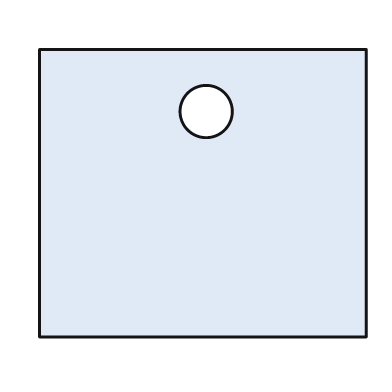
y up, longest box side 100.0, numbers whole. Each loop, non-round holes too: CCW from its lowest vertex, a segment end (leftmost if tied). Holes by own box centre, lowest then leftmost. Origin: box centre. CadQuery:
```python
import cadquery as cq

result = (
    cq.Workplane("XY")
    .moveTo(-50.0, -44.0)
    .lineTo(50.0, -44.0)
    .lineTo(50.0, 44.0)
    .lineTo(-50.0, 44.0)
    .close()
    .moveTo(1.0, 25.0)
    .circle(8.0)
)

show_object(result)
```